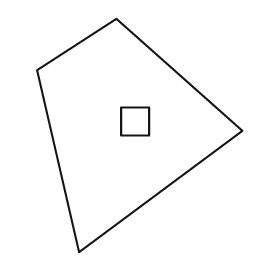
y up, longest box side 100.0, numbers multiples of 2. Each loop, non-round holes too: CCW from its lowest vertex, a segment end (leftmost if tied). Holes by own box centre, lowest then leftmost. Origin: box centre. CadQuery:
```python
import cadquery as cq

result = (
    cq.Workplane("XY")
    .moveTo(-26.0, -50.0)
    .lineTo(44.0, 2.0)
    .lineTo(-10.0, 50.0)
    .lineTo(-44.0, 28.0)
    .close()
    .moveTo(-8.0, 0.0)
    .lineTo(4.0, 0.0)
    .lineTo(4.0, 12.0)
    .lineTo(-8.0, 12.0)
    .close()
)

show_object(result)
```